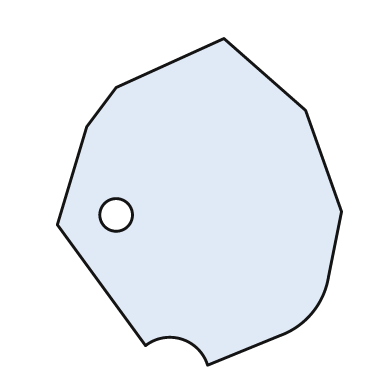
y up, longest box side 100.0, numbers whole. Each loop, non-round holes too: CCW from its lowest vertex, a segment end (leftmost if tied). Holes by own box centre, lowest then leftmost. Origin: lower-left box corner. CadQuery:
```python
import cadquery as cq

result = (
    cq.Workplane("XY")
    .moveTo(46.0, 0.0)
    .lineTo(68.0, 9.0)
    .threePointArc((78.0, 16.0), (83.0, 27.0))
    .lineTo(87.0, 47.0)
    .lineTo(76.0, 78.0)
    .lineTo(51.0, 100.0)
    .lineTo(18.0, 85.0)
    .lineTo(9.0, 73.0)
    .lineTo(0.0, 43.0)
    .lineTo(27.0, 6.0)
    .threePointArc((38.0, 8.0), (46.0, 0.0))
    .close()
    .moveTo(18.0, 46.0)
    .circle(5.0)
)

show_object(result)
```